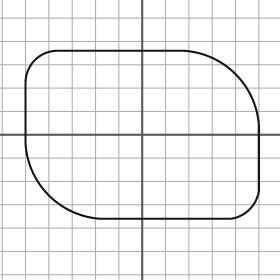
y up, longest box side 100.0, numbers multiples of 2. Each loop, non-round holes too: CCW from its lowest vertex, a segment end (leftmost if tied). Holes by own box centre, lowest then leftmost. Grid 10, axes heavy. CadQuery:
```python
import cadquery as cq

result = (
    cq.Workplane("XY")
    .moveTo(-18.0, -36.0)
    .lineTo(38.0, -36.0)
    .threePointArc((46.0, -32.0), (50.0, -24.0))
    .lineTo(50.0, 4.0)
    .threePointArc((40.0, 26.0), (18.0, 36.0))
    .lineTo(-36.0, 36.0)
    .threePointArc((-46.0, 32.0), (-50.0, 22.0))
    .lineTo(-50.0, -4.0)
    .threePointArc((-40.0, -26.0), (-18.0, -36.0))
    .close()
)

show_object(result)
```